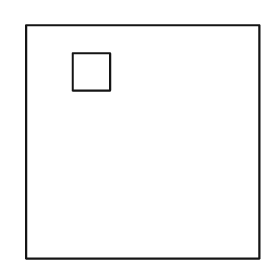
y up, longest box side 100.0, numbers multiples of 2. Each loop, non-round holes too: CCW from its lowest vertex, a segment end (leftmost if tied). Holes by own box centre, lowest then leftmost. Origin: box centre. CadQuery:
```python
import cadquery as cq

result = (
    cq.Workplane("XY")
    .moveTo(-50.0, -50.0)
    .lineTo(50.0, -50.0)
    .lineTo(50.0, 50.0)
    .lineTo(-50.0, 50.0)
    .close()
    .moveTo(-30.0, 22.0)
    .lineTo(-14.0, 22.0)
    .lineTo(-14.0, 38.0)
    .lineTo(-30.0, 38.0)
    .close()
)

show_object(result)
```